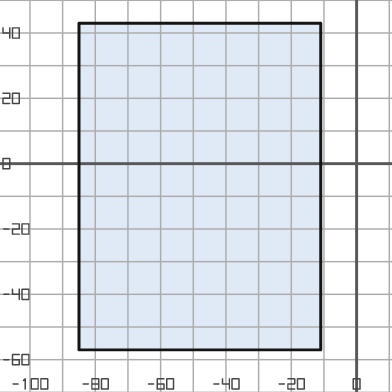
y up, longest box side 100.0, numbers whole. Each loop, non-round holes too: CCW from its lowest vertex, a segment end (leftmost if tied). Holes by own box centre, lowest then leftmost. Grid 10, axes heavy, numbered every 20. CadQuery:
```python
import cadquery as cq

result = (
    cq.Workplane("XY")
    .moveTo(-85.0, -57.0)
    .lineTo(-11.0, -57.0)
    .lineTo(-11.0, 43.0)
    .lineTo(-85.0, 43.0)
    .close()
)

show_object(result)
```